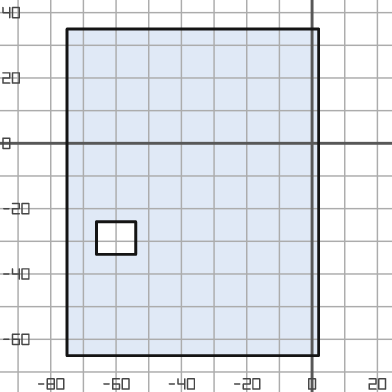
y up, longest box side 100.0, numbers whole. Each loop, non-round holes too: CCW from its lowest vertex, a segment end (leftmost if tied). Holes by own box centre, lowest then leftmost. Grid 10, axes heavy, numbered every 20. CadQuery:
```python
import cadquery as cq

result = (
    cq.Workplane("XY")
    .moveTo(-75.0, -65.0)
    .lineTo(2.0, -65.0)
    .lineTo(2.0, 35.0)
    .lineTo(-75.0, 35.0)
    .close()
    .moveTo(-66.0, -34.0)
    .lineTo(-54.0, -34.0)
    .lineTo(-54.0, -24.0)
    .lineTo(-66.0, -24.0)
    .close()
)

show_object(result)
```